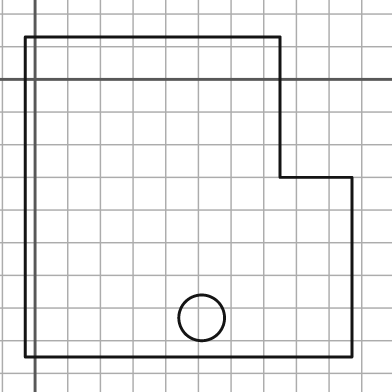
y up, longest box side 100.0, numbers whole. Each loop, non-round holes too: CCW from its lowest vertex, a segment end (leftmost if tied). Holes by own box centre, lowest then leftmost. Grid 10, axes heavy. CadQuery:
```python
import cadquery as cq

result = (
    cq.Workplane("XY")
    .moveTo(-3.0, -85.0)
    .lineTo(97.0, -85.0)
    .lineTo(97.0, -30.0)
    .lineTo(75.0, -30.0)
    .lineTo(75.0, 13.0)
    .lineTo(-3.0, 13.0)
    .close()
    .moveTo(51.0, -73.0)
    .circle(7.0)
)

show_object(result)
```